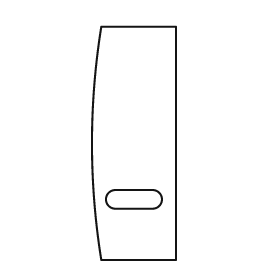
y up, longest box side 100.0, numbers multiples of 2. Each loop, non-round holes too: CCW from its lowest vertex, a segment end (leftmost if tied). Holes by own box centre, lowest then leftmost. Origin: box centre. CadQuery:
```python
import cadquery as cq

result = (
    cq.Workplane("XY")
    .moveTo(-14.0, -50.0)
    .lineTo(18.0, -50.0)
    .lineTo(18.0, 50.0)
    .lineTo(-14.0, 50.0)
    .threePointArc((-18.0, 0.0), (-14.0, -50.0))
    .close()
    .moveTo(-8.0, -28.0)
    .lineTo(8.0, -28.0)
    .threePointArc((12.0, -24.0), (8.0, -20.0))
    .lineTo(-8.0, -20.0)
    .threePointArc((-12.0, -24.0), (-8.0, -28.0))
    .close()
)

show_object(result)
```